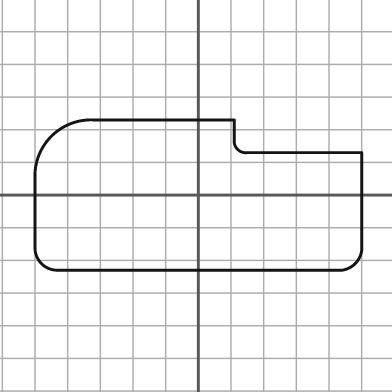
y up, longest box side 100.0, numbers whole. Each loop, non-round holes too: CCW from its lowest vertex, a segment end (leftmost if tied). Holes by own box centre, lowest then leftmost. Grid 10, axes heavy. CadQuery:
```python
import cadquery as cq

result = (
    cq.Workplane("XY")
    .moveTo(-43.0, -23.0)
    .lineTo(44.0, -23.0)
    .threePointArc((48.0, -21.0), (50.0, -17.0))
    .lineTo(50.0, 13.0)
    .lineTo(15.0, 13.0)
    .threePointArc((12.0, 14.0), (11.0, 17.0))
    .lineTo(11.0, 23.0)
    .lineTo(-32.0, 23.0)
    .threePointArc((-45.0, 18.0), (-50.0, 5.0))
    .lineTo(-50.0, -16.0)
    .threePointArc((-48.0, -21.0), (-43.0, -23.0))
    .close()
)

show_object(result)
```